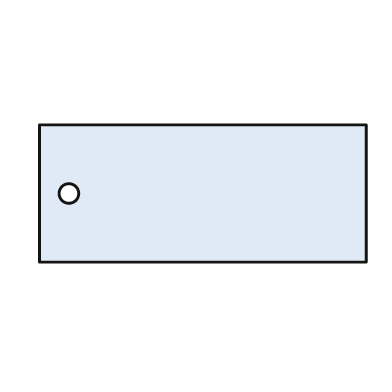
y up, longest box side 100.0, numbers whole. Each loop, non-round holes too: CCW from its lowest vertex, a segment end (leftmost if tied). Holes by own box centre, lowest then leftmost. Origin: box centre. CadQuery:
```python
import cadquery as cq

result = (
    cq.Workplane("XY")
    .moveTo(-50.0, -21.0)
    .lineTo(50.0, -21.0)
    .lineTo(50.0, 21.0)
    .lineTo(-50.0, 21.0)
    .close()
    .moveTo(-41.0, 0.0)
    .circle(3.0)
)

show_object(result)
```